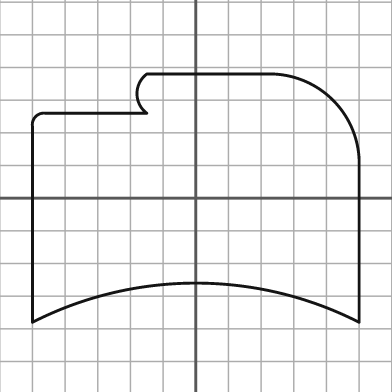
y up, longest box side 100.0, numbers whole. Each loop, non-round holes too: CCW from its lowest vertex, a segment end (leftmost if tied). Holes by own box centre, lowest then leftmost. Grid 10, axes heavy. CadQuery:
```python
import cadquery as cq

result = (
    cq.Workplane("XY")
    .moveTo(-50.0, -38.0)
    .threePointArc((0.0, -26.0), (50.0, -38.0))
    .lineTo(50.0, 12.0)
    .threePointArc((42.0, 30.0), (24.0, 38.0))
    .lineTo(-15.0, 38.0)
    .threePointArc((-18.0, 32.0), (-15.0, 26.0))
    .lineTo(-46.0, 26.0)
    .threePointArc((-49.0, 25.0), (-50.0, 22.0))
    .close()
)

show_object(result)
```